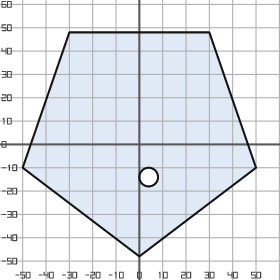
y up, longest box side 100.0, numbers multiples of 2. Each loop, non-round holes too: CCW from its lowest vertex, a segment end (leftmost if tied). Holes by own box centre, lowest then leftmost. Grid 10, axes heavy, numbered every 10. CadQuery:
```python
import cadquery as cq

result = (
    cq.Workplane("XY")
    .moveTo(0.0, -48.0)
    .lineTo(50.0, -10.0)
    .lineTo(30.0, 48.0)
    .lineTo(-30.0, 48.0)
    .lineTo(-50.0, -10.0)
    .close()
    .moveTo(4.0, -14.0)
    .circle(4.0)
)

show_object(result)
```